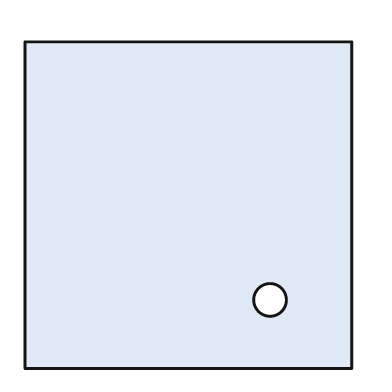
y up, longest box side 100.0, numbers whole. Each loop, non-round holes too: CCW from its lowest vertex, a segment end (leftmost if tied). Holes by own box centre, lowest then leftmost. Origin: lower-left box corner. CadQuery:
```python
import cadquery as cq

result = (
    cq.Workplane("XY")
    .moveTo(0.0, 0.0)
    .lineTo(100.0, 0.0)
    .lineTo(100.0, 100.0)
    .lineTo(0.0, 100.0)
    .close()
    .moveTo(75.0, 21.0)
    .circle(5.0)
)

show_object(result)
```